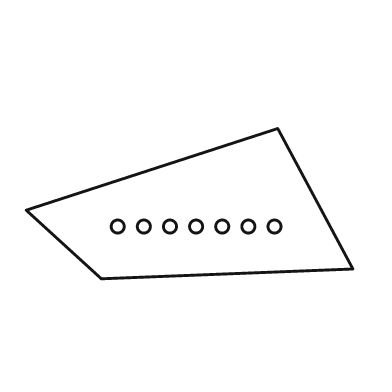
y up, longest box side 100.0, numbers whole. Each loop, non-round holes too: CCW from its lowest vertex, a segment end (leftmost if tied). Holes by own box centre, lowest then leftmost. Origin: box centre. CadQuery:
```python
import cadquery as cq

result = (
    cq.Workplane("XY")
    .moveTo(-27.0, -23.0)
    .lineTo(50.0, -20.0)
    .lineTo(27.0, 23.0)
    .lineTo(-50.0, -2.0)
    .close()
    .moveTo(-22.0, -7.0)
    .circle(2.0)
    .moveTo(-14.0, -7.0)
    .circle(2.0)
    .moveTo(-6.0, -7.0)
    .circle(2.0)
    .moveTo(2.0, -7.0)
    .circle(2.0)
    .moveTo(10.0, -7.0)
    .circle(2.0)
    .moveTo(18.0, -7.0)
    .circle(2.0)
    .moveTo(26.0, -7.0)
    .circle(2.0)
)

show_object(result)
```